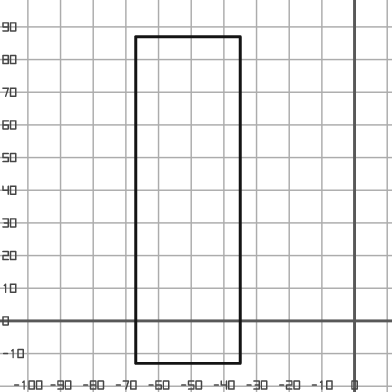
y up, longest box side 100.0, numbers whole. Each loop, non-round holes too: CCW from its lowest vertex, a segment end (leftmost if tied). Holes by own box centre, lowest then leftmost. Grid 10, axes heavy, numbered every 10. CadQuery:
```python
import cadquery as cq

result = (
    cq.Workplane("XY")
    .moveTo(-67.0, -13.0)
    .lineTo(-35.0, -13.0)
    .lineTo(-35.0, 87.0)
    .lineTo(-67.0, 87.0)
    .close()
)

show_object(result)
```